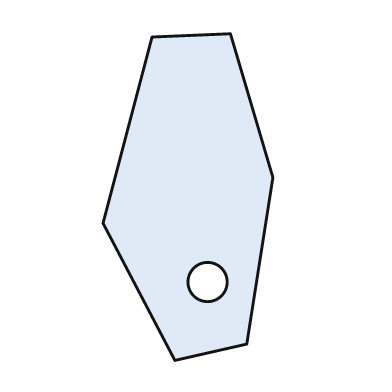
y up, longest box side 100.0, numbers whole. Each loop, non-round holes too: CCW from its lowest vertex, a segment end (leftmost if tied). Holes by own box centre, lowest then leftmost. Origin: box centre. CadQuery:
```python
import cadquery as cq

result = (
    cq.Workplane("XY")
    .moveTo(-4.0, -50.0)
    .lineTo(18.0, -45.0)
    .lineTo(26.0, 6.0)
    .lineTo(13.0, 50.0)
    .lineTo(-11.0, 49.0)
    .lineTo(-26.0, -8.0)
    .close()
    .moveTo(6.0, -26.0)
    .circle(6.0)
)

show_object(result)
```